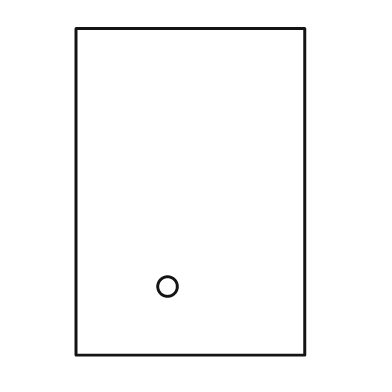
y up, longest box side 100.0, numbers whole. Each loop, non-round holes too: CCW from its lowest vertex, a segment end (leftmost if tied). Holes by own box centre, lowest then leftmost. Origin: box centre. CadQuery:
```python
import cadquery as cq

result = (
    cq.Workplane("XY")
    .moveTo(-35.0, -50.0)
    .lineTo(35.0, -50.0)
    .lineTo(35.0, 50.0)
    .lineTo(-35.0, 50.0)
    .close()
    .moveTo(-7.0, -29.0)
    .circle(3.0)
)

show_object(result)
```